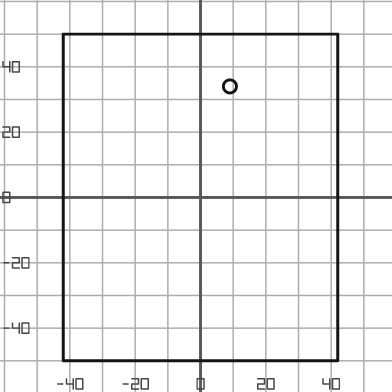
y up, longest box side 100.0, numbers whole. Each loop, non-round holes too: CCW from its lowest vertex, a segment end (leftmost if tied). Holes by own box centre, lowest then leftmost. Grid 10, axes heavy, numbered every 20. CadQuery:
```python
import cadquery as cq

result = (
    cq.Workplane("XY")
    .moveTo(-42.0, -50.0)
    .lineTo(42.0, -50.0)
    .lineTo(42.0, 50.0)
    .lineTo(-42.0, 50.0)
    .close()
    .moveTo(9.0, 34.0)
    .circle(2.0)
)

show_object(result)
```